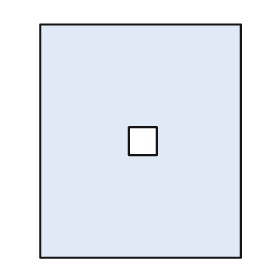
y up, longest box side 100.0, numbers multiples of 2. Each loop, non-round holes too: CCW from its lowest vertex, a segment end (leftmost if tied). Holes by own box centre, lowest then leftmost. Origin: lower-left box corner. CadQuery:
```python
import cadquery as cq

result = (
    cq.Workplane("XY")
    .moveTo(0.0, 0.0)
    .lineTo(86.0, 0.0)
    .lineTo(86.0, 100.0)
    .lineTo(0.0, 100.0)
    .close()
    .moveTo(38.0, 44.0)
    .lineTo(50.0, 44.0)
    .lineTo(50.0, 56.0)
    .lineTo(38.0, 56.0)
    .close()
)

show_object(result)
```